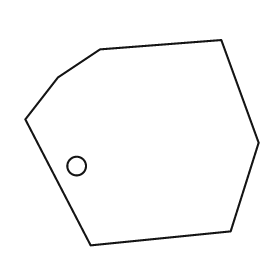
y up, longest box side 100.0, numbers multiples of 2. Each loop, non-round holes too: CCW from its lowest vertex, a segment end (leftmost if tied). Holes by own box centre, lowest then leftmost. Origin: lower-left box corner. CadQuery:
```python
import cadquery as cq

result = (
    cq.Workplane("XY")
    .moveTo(28.0, 0.0)
    .lineTo(88.0, 6.0)
    .lineTo(100.0, 44.0)
    .lineTo(84.0, 88.0)
    .lineTo(32.0, 84.0)
    .lineTo(14.0, 72.0)
    .lineTo(0.0, 54.0)
    .close()
    .moveTo(22.0, 34.0)
    .circle(4.0)
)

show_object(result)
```